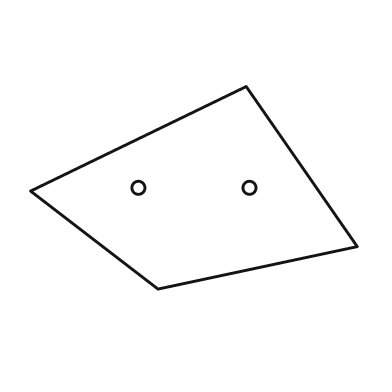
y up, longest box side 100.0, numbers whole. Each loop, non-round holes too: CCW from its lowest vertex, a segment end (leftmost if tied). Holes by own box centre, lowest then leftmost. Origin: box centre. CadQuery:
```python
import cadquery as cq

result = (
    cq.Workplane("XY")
    .moveTo(-11.0, -31.0)
    .lineTo(50.0, -18.0)
    .lineTo(16.0, 31.0)
    .lineTo(-50.0, -1.0)
    .close()
    .moveTo(-17.0, 0.0)
    .circle(2.0)
    .moveTo(17.0, 0.0)
    .circle(2.0)
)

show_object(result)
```